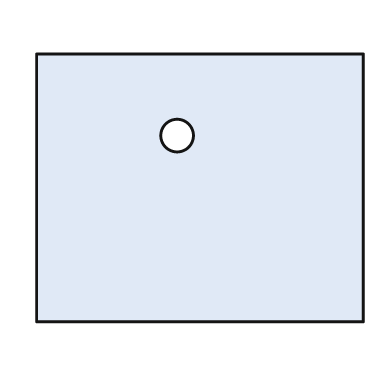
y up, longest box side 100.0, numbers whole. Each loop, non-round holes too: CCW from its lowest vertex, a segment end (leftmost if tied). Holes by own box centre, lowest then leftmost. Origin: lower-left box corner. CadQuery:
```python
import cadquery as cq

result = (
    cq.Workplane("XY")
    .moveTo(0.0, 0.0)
    .lineTo(100.0, 0.0)
    .lineTo(100.0, 82.0)
    .lineTo(0.0, 82.0)
    .close()
    .moveTo(43.0, 57.0)
    .circle(5.0)
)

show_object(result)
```